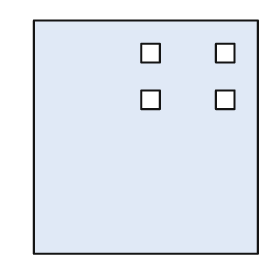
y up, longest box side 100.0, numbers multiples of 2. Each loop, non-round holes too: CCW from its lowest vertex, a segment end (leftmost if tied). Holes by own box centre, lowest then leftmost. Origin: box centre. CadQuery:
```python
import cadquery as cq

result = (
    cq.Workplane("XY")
    .moveTo(-48.0, -50.0)
    .lineTo(48.0, -50.0)
    .lineTo(48.0, 50.0)
    .lineTo(-48.0, 50.0)
    .close()
    .moveTo(-2.0, 12.0)
    .lineTo(6.0, 12.0)
    .lineTo(6.0, 20.0)
    .lineTo(-2.0, 20.0)
    .close()
    .moveTo(30.0, 12.0)
    .lineTo(38.0, 12.0)
    .lineTo(38.0, 20.0)
    .lineTo(30.0, 20.0)
    .close()
    .moveTo(-2.0, 32.0)
    .lineTo(6.0, 32.0)
    .lineTo(6.0, 40.0)
    .lineTo(-2.0, 40.0)
    .close()
    .moveTo(30.0, 32.0)
    .lineTo(38.0, 32.0)
    .lineTo(38.0, 40.0)
    .lineTo(30.0, 40.0)
    .close()
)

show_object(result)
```